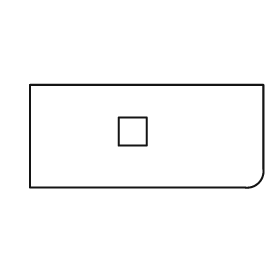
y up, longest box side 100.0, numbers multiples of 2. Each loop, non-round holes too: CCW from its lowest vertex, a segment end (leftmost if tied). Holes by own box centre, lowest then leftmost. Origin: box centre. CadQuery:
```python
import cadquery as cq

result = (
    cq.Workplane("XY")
    .moveTo(-50.0, -22.0)
    .lineTo(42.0, -22.0)
    .threePointArc((48.0, -20.0), (50.0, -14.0))
    .lineTo(50.0, 22.0)
    .lineTo(-50.0, 22.0)
    .close()
    .moveTo(-12.0, -4.0)
    .lineTo(0.0, -4.0)
    .lineTo(0.0, 8.0)
    .lineTo(-12.0, 8.0)
    .close()
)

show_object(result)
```